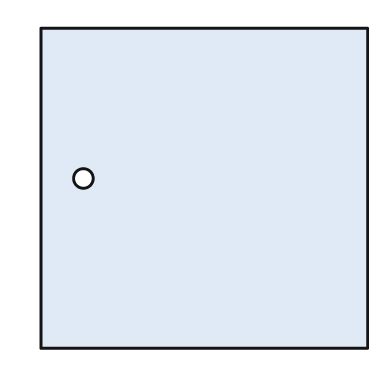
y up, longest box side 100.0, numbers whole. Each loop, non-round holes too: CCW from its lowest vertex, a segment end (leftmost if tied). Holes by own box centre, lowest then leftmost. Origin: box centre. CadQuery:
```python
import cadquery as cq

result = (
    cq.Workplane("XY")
    .moveTo(-50.0, -49.0)
    .lineTo(50.0, -49.0)
    .lineTo(50.0, 49.0)
    .lineTo(-50.0, 49.0)
    .close()
    .moveTo(-37.0, 3.0)
    .circle(3.0)
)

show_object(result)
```